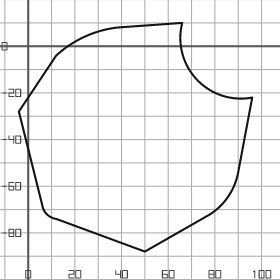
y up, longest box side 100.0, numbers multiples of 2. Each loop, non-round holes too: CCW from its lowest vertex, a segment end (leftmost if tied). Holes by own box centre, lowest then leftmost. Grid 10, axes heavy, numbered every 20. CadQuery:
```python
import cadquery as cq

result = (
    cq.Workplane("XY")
    .moveTo(50.0, -88.0)
    .lineTo(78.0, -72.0)
    .threePointArc((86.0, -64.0), (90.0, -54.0))
    .lineTo(96.0, -22.0)
    .threePointArc((72.0, -14.0), (66.0, 10.0))
    .lineTo(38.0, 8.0)
    .threePointArc((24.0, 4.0), (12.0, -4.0))
    .lineTo(-4.0, -28.0)
    .lineTo(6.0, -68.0)
    .threePointArc((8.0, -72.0), (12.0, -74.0))
    .close()
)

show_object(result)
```